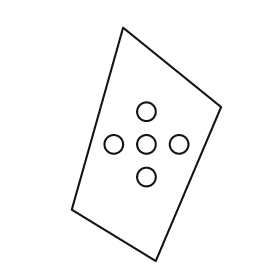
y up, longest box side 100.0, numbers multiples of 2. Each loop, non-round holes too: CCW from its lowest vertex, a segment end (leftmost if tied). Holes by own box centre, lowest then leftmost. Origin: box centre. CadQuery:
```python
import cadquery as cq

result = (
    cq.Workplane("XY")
    .moveTo(4.0, -50.0)
    .lineTo(32.0, 16.0)
    .lineTo(-10.0, 50.0)
    .lineTo(-32.0, -28.0)
    .close()
    .moveTo(0.0, -14.0)
    .circle(4.0)
    .moveTo(-14.0, 0.0)
    .circle(4.0)
    .moveTo(0.0, 0.0)
    .circle(4.0)
    .moveTo(14.0, 0.0)
    .circle(4.0)
    .moveTo(0.0, 14.0)
    .circle(4.0)
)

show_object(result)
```